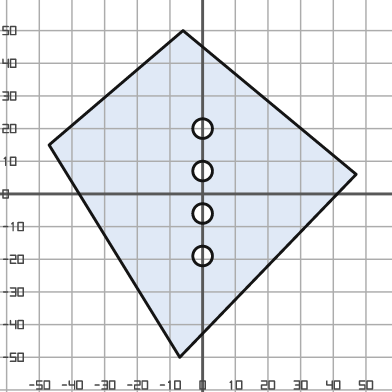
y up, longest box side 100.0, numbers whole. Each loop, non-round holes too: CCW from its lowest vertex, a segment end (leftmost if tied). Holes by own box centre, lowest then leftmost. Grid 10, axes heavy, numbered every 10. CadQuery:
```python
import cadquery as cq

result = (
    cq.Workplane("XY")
    .moveTo(-7.0, -50.0)
    .lineTo(47.0, 6.0)
    .lineTo(-6.0, 50.0)
    .lineTo(-47.0, 15.0)
    .close()
    .moveTo(0.0, -19.0)
    .circle(3.0)
    .moveTo(0.0, -6.0)
    .circle(3.0)
    .moveTo(0.0, 7.0)
    .circle(3.0)
    .moveTo(0.0, 20.0)
    .circle(3.0)
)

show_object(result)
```